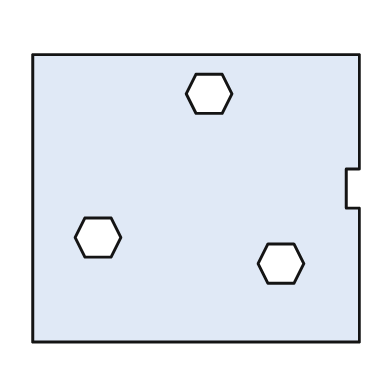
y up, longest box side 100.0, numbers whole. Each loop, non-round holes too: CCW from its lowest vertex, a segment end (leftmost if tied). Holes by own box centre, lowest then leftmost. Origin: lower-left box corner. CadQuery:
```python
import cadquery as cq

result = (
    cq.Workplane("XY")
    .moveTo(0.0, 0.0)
    .lineTo(100.0, 0.0)
    .lineTo(100.0, 41.0)
    .lineTo(96.0, 41.0)
    .lineTo(96.0, 53.0)
    .lineTo(100.0, 53.0)
    .lineTo(100.0, 88.0)
    .lineTo(0.0, 88.0)
    .close()
    .moveTo(72.0, 18.0)
    .lineTo(80.0, 18.0)
    .lineTo(83.0, 24.0)
    .lineTo(80.0, 30.0)
    .lineTo(72.0, 30.0)
    .lineTo(69.0, 24.0)
    .close()
    .moveTo(16.0, 26.0)
    .lineTo(24.0, 26.0)
    .lineTo(27.0, 32.0)
    .lineTo(24.0, 38.0)
    .lineTo(16.0, 38.0)
    .lineTo(13.0, 32.0)
    .close()
    .moveTo(50.0, 70.0)
    .lineTo(58.0, 70.0)
    .lineTo(61.0, 76.0)
    .lineTo(58.0, 82.0)
    .lineTo(50.0, 82.0)
    .lineTo(47.0, 76.0)
    .close()
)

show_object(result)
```